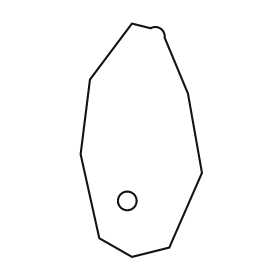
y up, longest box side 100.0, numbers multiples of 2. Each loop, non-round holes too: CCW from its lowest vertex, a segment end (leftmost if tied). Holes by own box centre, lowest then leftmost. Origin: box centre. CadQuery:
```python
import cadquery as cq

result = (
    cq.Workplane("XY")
    .moveTo(-4.0, -50.0)
    .lineTo(12.0, -46.0)
    .lineTo(26.0, -14.0)
    .lineTo(20.0, 20.0)
    .lineTo(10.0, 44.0)
    .threePointArc((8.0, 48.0), (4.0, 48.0))
    .lineTo(-4.0, 50.0)
    .lineTo(-22.0, 26.0)
    .lineTo(-26.0, -6.0)
    .lineTo(-18.0, -42.0)
    .close()
    .moveTo(-6.0, -26.0)
    .circle(4.0)
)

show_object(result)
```